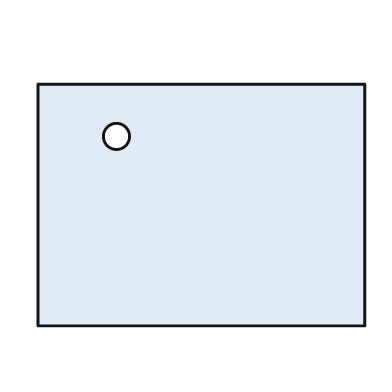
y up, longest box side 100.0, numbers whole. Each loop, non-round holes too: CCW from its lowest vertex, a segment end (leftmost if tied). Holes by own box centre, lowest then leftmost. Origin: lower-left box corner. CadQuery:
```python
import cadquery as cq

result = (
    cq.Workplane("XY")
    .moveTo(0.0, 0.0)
    .lineTo(100.0, 0.0)
    .lineTo(100.0, 74.0)
    .lineTo(0.0, 74.0)
    .close()
    .moveTo(24.0, 58.0)
    .circle(4.0)
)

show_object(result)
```